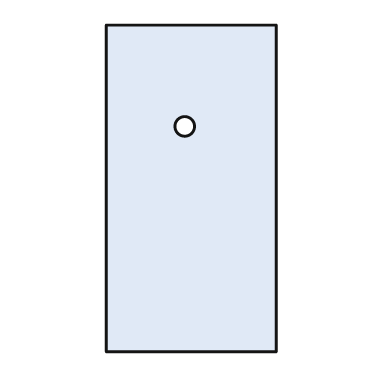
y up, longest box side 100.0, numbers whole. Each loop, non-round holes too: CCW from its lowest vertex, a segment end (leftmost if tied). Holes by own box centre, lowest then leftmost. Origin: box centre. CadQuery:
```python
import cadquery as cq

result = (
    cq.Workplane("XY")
    .moveTo(-26.0, -50.0)
    .lineTo(26.0, -50.0)
    .lineTo(26.0, 50.0)
    .lineTo(-26.0, 50.0)
    .close()
    .moveTo(-2.0, 19.0)
    .circle(3.0)
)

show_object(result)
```